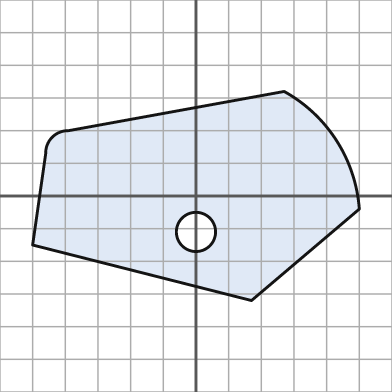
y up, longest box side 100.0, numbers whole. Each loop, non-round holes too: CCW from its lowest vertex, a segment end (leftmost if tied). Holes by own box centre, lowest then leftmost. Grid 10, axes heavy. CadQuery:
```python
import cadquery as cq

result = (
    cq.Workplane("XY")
    .moveTo(17.0, -32.0)
    .lineTo(50.0, -4.0)
    .threePointArc((43.0, 17.0), (27.0, 32.0))
    .lineTo(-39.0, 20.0)
    .threePointArc((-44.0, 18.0), (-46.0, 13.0))
    .lineTo(-50.0, -15.0)
    .close()
    .moveTo(0.0, -11.0)
    .circle(6.0)
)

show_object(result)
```